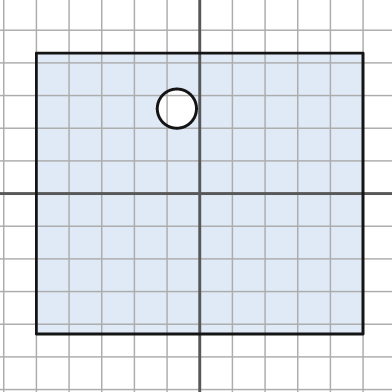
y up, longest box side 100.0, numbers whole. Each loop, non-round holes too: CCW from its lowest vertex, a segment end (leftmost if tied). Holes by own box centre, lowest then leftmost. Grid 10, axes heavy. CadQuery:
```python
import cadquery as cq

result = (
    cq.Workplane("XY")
    .moveTo(-50.0, -43.0)
    .lineTo(50.0, -43.0)
    .lineTo(50.0, 43.0)
    .lineTo(-50.0, 43.0)
    .close()
    .moveTo(-7.0, 26.0)
    .circle(6.0)
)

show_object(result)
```